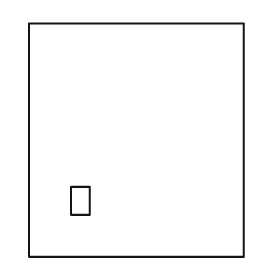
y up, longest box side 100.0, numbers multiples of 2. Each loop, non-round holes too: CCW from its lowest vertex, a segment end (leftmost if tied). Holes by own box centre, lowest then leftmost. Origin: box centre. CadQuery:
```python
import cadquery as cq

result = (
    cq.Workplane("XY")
    .moveTo(-46.0, -50.0)
    .lineTo(46.0, -50.0)
    .lineTo(46.0, 50.0)
    .lineTo(-46.0, 50.0)
    .close()
    .moveTo(-28.0, -32.0)
    .lineTo(-20.0, -32.0)
    .lineTo(-20.0, -20.0)
    .lineTo(-28.0, -20.0)
    .close()
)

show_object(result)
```